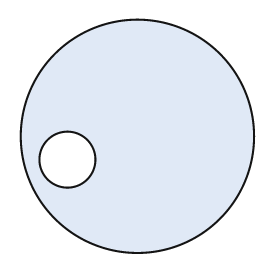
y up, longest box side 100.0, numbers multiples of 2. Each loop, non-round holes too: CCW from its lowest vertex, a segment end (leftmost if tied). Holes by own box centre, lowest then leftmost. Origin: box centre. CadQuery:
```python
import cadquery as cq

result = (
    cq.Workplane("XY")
    .moveTo(0.0, 0.0)
    .circle(50.0)
    .moveTo(-30.0, -10.0)
    .circle(12.0)
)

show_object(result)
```